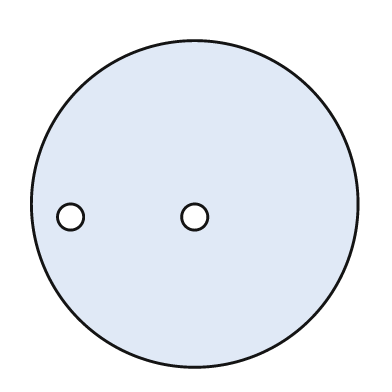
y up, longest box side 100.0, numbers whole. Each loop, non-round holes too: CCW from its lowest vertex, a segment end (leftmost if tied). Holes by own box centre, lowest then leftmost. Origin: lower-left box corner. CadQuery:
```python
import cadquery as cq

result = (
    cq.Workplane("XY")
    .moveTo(50.0, 50.0)
    .circle(50.0)
    .moveTo(12.0, 46.0)
    .circle(4.0)
    .moveTo(50.0, 46.0)
    .circle(4.0)
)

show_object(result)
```